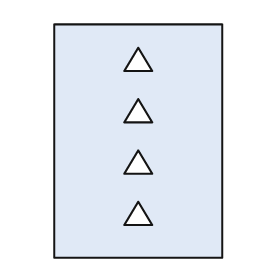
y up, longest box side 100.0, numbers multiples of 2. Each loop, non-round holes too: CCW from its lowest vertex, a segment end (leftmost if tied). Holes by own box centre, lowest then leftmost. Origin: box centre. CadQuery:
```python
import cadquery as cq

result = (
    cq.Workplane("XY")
    .moveTo(-36.0, -50.0)
    .lineTo(36.0, -50.0)
    .lineTo(36.0, 50.0)
    .lineTo(-36.0, 50.0)
    .close()
    .moveTo(-6.0, -36.0)
    .lineTo(6.0, -36.0)
    .lineTo(0.0, -26.0)
    .close()
    .moveTo(-6.0, -14.0)
    .lineTo(6.0, -14.0)
    .lineTo(0.0, -4.0)
    .close()
    .moveTo(-6.0, 8.0)
    .lineTo(6.0, 8.0)
    .lineTo(0.0, 18.0)
    .close()
    .moveTo(-6.0, 30.0)
    .lineTo(6.0, 30.0)
    .lineTo(0.0, 40.0)
    .close()
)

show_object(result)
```